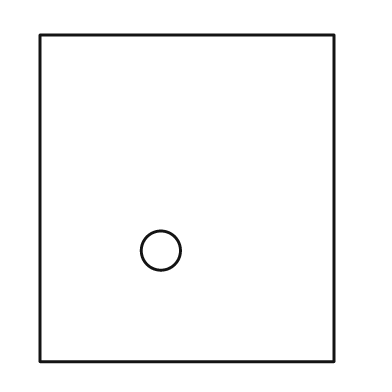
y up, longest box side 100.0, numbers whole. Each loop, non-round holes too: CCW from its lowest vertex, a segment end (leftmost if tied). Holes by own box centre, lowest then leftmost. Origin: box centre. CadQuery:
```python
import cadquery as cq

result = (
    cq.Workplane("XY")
    .moveTo(-45.0, -50.0)
    .lineTo(45.0, -50.0)
    .lineTo(45.0, 50.0)
    .lineTo(-45.0, 50.0)
    .close()
    .moveTo(-8.0, -16.0)
    .circle(6.0)
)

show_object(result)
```